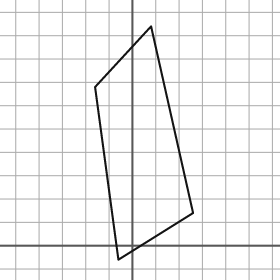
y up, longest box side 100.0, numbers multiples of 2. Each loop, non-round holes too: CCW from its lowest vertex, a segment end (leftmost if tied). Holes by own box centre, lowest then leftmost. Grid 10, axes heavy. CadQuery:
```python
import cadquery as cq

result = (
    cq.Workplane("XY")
    .moveTo(-6.0, -6.0)
    .lineTo(26.0, 14.0)
    .lineTo(8.0, 94.0)
    .lineTo(-16.0, 68.0)
    .close()
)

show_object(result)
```